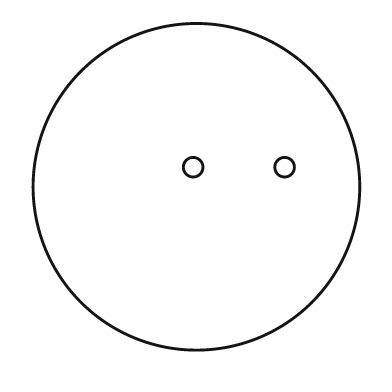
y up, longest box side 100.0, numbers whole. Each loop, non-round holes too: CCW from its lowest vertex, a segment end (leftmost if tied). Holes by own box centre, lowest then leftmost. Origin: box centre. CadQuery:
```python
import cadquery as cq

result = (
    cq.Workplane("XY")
    .moveTo(0.0, 0.0)
    .circle(50.0)
    .moveTo(-1.0, 6.0)
    .circle(3.0)
    .moveTo(27.0, 6.0)
    .circle(3.0)
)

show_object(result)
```